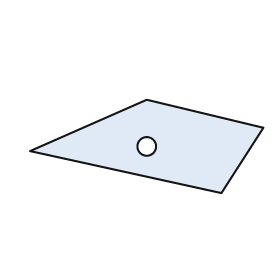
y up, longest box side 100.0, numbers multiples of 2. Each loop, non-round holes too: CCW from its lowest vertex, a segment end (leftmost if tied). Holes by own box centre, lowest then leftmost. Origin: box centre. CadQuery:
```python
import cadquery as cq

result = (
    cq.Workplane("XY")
    .moveTo(32.0, -20.0)
    .lineTo(50.0, 8.0)
    .lineTo(0.0, 20.0)
    .lineTo(-50.0, -2.0)
    .close()
    .moveTo(0.0, 0.0)
    .circle(4.0)
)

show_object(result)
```